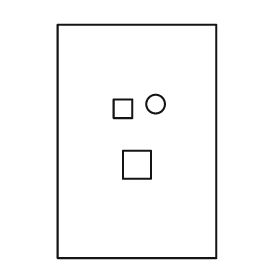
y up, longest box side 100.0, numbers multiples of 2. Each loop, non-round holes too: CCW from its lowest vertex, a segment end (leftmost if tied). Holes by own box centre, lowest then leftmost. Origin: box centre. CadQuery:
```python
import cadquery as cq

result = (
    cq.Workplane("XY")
    .moveTo(-34.0, -50.0)
    .lineTo(34.0, -50.0)
    .lineTo(34.0, 50.0)
    .lineTo(-34.0, 50.0)
    .close()
    .moveTo(-6.0, -16.0)
    .lineTo(6.0, -16.0)
    .lineTo(6.0, -4.0)
    .lineTo(-6.0, -4.0)
    .close()
    .moveTo(-10.0, 10.0)
    .lineTo(-2.0, 10.0)
    .lineTo(-2.0, 18.0)
    .lineTo(-10.0, 18.0)
    .close()
    .moveTo(8.0, 16.0)
    .circle(4.0)
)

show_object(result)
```